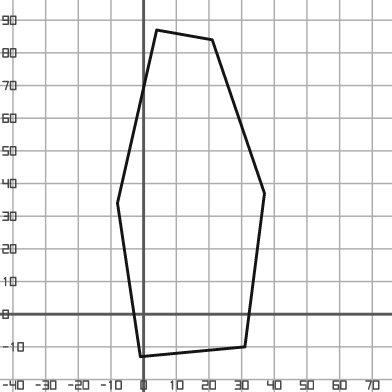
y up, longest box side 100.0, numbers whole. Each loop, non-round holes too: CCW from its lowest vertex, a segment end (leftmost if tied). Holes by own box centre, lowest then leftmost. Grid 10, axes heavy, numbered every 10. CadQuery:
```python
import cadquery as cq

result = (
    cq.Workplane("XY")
    .moveTo(-1.0, -13.0)
    .lineTo(31.0, -10.0)
    .lineTo(37.0, 37.0)
    .lineTo(21.0, 84.0)
    .lineTo(4.0, 87.0)
    .lineTo(-8.0, 34.0)
    .close()
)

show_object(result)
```